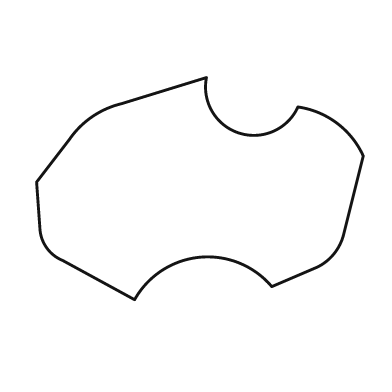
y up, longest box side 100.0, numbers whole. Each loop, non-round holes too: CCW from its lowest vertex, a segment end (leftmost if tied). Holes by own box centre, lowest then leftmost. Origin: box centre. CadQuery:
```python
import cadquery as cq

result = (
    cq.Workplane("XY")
    .moveTo(-20.0, -34.0)
    .threePointArc((0.0, -21.0), (22.0, -30.0))
    .lineTo(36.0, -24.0)
    .threePointArc((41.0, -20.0), (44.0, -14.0))
    .lineTo(50.0, 10.0)
    .threePointArc((42.0, 20.0), (30.0, 25.0))
    .threePointArc((12.0, 17.0), (2.0, 34.0))
    .lineTo(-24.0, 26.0)
    .threePointArc((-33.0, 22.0), (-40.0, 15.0))
    .lineTo(-50.0, 2.0)
    .lineTo(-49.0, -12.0)
    .threePointArc((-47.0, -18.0), (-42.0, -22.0))
    .close()
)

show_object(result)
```